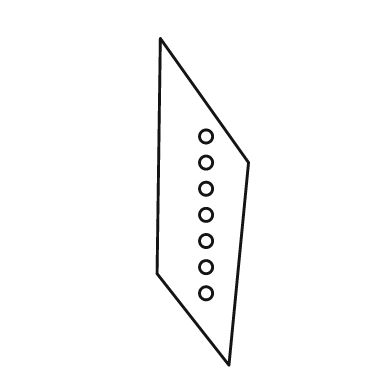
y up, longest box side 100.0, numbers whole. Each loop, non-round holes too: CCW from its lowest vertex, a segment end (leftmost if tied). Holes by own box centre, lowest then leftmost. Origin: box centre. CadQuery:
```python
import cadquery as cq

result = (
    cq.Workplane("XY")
    .moveTo(8.0, -50.0)
    .lineTo(14.0, 12.0)
    .lineTo(-13.0, 50.0)
    .lineTo(-14.0, -22.0)
    .close()
    .moveTo(1.0, -28.0)
    .circle(2.0)
    .moveTo(1.0, -20.0)
    .circle(2.0)
    .moveTo(1.0, -12.0)
    .circle(2.0)
    .moveTo(1.0, -4.0)
    .circle(2.0)
    .moveTo(1.0, 4.0)
    .circle(2.0)
    .moveTo(1.0, 12.0)
    .circle(2.0)
    .moveTo(1.0, 20.0)
    .circle(2.0)
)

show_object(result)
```